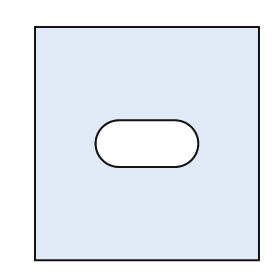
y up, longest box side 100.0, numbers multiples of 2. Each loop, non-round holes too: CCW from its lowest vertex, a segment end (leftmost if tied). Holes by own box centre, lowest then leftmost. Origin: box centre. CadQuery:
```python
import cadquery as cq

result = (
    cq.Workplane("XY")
    .moveTo(-48.0, -50.0)
    .lineTo(48.0, -50.0)
    .lineTo(48.0, 50.0)
    .lineTo(-48.0, 50.0)
    .close()
    .moveTo(-12.0, -10.0)
    .lineTo(12.0, -10.0)
    .threePointArc((22.0, 0.0), (12.0, 10.0))
    .lineTo(-12.0, 10.0)
    .threePointArc((-22.0, 0.0), (-12.0, -10.0))
    .close()
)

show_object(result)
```